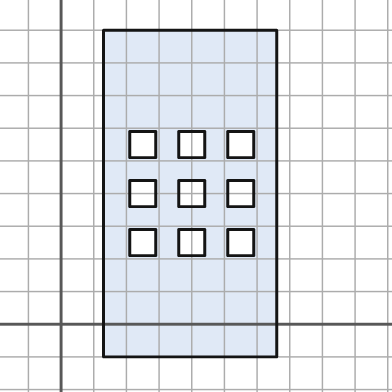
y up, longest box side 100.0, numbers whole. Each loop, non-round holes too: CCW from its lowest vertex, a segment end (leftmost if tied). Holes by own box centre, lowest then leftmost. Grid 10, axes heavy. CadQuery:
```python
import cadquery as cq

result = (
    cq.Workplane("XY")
    .moveTo(13.0, -10.0)
    .lineTo(66.0, -10.0)
    .lineTo(66.0, 90.0)
    .lineTo(13.0, 90.0)
    .close()
    .moveTo(21.0, 21.0)
    .lineTo(29.0, 21.0)
    .lineTo(29.0, 29.0)
    .lineTo(21.0, 29.0)
    .close()
    .moveTo(36.0, 21.0)
    .lineTo(44.0, 21.0)
    .lineTo(44.0, 29.0)
    .lineTo(36.0, 29.0)
    .close()
    .moveTo(51.0, 21.0)
    .lineTo(59.0, 21.0)
    .lineTo(59.0, 29.0)
    .lineTo(51.0, 29.0)
    .close()
    .moveTo(21.0, 36.0)
    .lineTo(29.0, 36.0)
    .lineTo(29.0, 44.0)
    .lineTo(21.0, 44.0)
    .close()
    .moveTo(36.0, 36.0)
    .lineTo(44.0, 36.0)
    .lineTo(44.0, 44.0)
    .lineTo(36.0, 44.0)
    .close()
    .moveTo(51.0, 36.0)
    .lineTo(59.0, 36.0)
    .lineTo(59.0, 44.0)
    .lineTo(51.0, 44.0)
    .close()
    .moveTo(21.0, 51.0)
    .lineTo(29.0, 51.0)
    .lineTo(29.0, 59.0)
    .lineTo(21.0, 59.0)
    .close()
    .moveTo(36.0, 51.0)
    .lineTo(44.0, 51.0)
    .lineTo(44.0, 59.0)
    .lineTo(36.0, 59.0)
    .close()
    .moveTo(51.0, 51.0)
    .lineTo(59.0, 51.0)
    .lineTo(59.0, 59.0)
    .lineTo(51.0, 59.0)
    .close()
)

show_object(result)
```